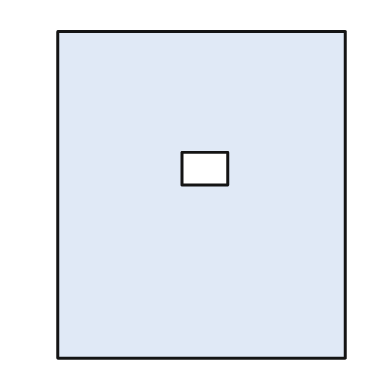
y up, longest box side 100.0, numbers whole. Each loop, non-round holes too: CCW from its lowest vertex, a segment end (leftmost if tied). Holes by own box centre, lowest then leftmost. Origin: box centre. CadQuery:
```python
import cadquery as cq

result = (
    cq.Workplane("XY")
    .moveTo(-44.0, -50.0)
    .lineTo(44.0, -50.0)
    .lineTo(44.0, 50.0)
    .lineTo(-44.0, 50.0)
    .close()
    .moveTo(-6.0, 3.0)
    .lineTo(8.0, 3.0)
    .lineTo(8.0, 13.0)
    .lineTo(-6.0, 13.0)
    .close()
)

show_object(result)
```